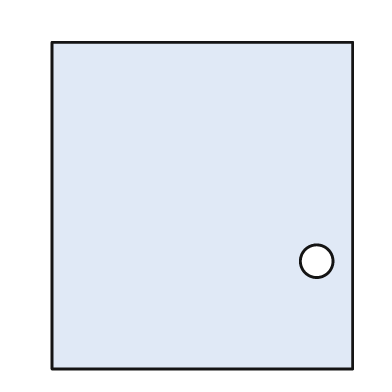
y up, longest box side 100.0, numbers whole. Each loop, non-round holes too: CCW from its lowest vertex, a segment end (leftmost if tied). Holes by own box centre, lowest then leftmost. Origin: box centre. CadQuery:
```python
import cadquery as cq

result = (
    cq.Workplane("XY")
    .moveTo(-46.0, -50.0)
    .lineTo(46.0, -50.0)
    .lineTo(46.0, 50.0)
    .lineTo(-46.0, 50.0)
    .close()
    .moveTo(35.0, -17.0)
    .circle(5.0)
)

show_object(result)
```